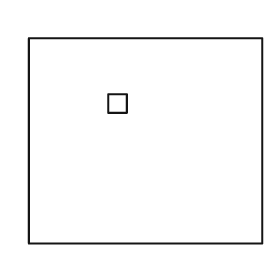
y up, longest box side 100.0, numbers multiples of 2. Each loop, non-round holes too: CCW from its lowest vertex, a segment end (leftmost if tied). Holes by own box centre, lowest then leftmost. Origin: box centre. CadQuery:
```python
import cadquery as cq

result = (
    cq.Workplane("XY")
    .moveTo(-50.0, -44.0)
    .lineTo(50.0, -44.0)
    .lineTo(50.0, 44.0)
    .lineTo(-50.0, 44.0)
    .close()
    .moveTo(-16.0, 12.0)
    .lineTo(-8.0, 12.0)
    .lineTo(-8.0, 20.0)
    .lineTo(-16.0, 20.0)
    .close()
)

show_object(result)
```